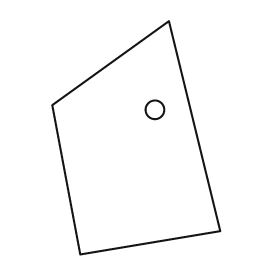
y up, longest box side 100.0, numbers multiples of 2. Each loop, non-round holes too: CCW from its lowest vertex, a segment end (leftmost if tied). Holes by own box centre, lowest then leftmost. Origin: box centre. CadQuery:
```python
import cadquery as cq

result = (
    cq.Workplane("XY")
    .moveTo(-24.0, -50.0)
    .lineTo(36.0, -40.0)
    .lineTo(14.0, 50.0)
    .lineTo(-36.0, 14.0)
    .close()
    .moveTo(8.0, 12.0)
    .circle(4.0)
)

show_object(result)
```